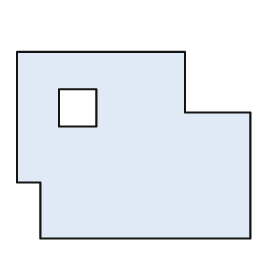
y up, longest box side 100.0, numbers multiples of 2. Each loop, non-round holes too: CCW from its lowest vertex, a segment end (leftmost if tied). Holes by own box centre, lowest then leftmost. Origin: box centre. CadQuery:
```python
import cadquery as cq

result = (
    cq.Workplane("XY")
    .moveTo(-40.0, -40.0)
    .lineTo(50.0, -40.0)
    .lineTo(50.0, 14.0)
    .lineTo(22.0, 14.0)
    .lineTo(22.0, 40.0)
    .lineTo(-50.0, 40.0)
    .lineTo(-50.0, -16.0)
    .lineTo(-40.0, -16.0)
    .close()
    .moveTo(-32.0, 8.0)
    .lineTo(-16.0, 8.0)
    .lineTo(-16.0, 24.0)
    .lineTo(-32.0, 24.0)
    .close()
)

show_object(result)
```